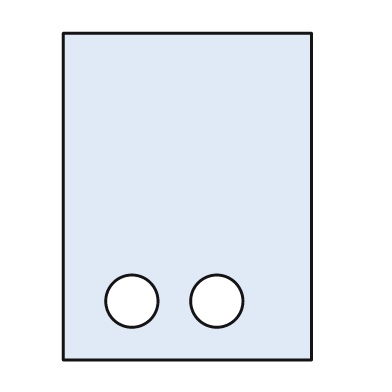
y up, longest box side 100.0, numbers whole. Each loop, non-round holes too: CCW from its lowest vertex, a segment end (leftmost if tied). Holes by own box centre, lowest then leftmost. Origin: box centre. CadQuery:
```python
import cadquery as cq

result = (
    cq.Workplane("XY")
    .moveTo(-38.0, -50.0)
    .lineTo(38.0, -50.0)
    .lineTo(38.0, 50.0)
    .lineTo(-38.0, 50.0)
    .close()
    .moveTo(-17.0, -32.0)
    .circle(8.0)
    .moveTo(9.0, -32.0)
    .circle(8.0)
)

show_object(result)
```